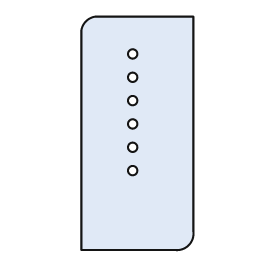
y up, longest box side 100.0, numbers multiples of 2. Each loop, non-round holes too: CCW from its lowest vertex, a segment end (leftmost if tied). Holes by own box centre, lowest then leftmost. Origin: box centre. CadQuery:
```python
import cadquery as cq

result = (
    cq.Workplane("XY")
    .moveTo(-24.0, -50.0)
    .lineTo(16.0, -50.0)
    .threePointArc((22.0, -48.0), (24.0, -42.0))
    .lineTo(24.0, 50.0)
    .lineTo(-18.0, 50.0)
    .threePointArc((-22.0, 48.0), (-24.0, 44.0))
    .close()
    .moveTo(-2.0, -16.0)
    .circle(2.0)
    .moveTo(-2.0, -6.0)
    .circle(2.0)
    .moveTo(-2.0, 4.0)
    .circle(2.0)
    .moveTo(-2.0, 14.0)
    .circle(2.0)
    .moveTo(-2.0, 24.0)
    .circle(2.0)
    .moveTo(-2.0, 34.0)
    .circle(2.0)
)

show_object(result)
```